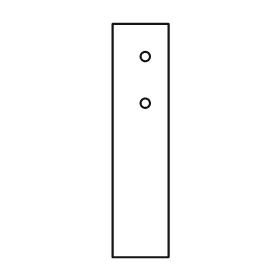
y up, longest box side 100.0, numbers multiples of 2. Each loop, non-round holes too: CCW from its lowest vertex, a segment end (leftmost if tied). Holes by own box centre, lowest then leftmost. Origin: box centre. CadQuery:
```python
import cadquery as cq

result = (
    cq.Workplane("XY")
    .moveTo(-12.0, -50.0)
    .lineTo(12.0, -50.0)
    .lineTo(12.0, 50.0)
    .lineTo(-12.0, 50.0)
    .close()
    .moveTo(2.0, 16.0)
    .circle(2.0)
    .moveTo(2.0, 36.0)
    .circle(2.0)
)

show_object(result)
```